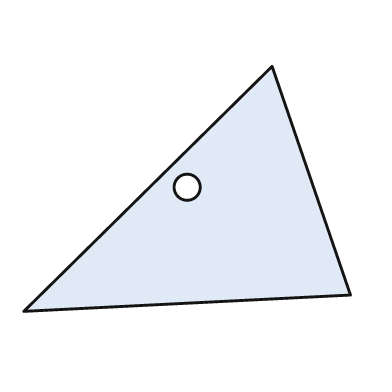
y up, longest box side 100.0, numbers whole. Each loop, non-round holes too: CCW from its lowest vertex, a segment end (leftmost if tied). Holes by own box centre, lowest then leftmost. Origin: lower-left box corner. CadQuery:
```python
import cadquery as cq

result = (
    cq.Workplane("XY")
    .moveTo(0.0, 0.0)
    .lineTo(100.0, 5.0)
    .lineTo(76.0, 75.0)
    .close()
    .moveTo(50.0, 38.0)
    .circle(4.0)
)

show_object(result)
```